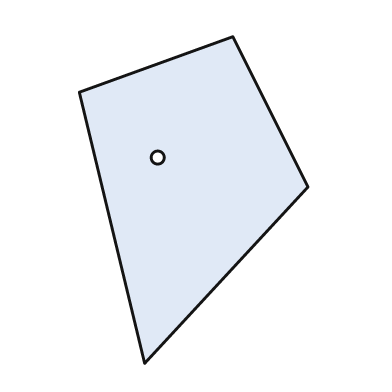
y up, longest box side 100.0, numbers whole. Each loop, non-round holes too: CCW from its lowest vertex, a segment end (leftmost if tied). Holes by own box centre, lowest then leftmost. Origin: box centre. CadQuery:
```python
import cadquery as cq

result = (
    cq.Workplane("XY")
    .moveTo(-15.0, -50.0)
    .lineTo(35.0, 4.0)
    .lineTo(12.0, 50.0)
    .lineTo(-35.0, 33.0)
    .close()
    .moveTo(-11.0, 13.0)
    .circle(2.0)
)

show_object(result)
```